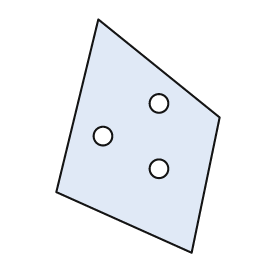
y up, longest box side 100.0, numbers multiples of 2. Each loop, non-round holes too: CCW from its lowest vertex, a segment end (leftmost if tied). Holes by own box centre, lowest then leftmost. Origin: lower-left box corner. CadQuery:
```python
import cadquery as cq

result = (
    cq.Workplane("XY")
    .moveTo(58.0, 0.0)
    .lineTo(70.0, 58.0)
    .lineTo(18.0, 100.0)
    .lineTo(0.0, 26.0)
    .close()
    .moveTo(44.0, 36.0)
    .circle(4.0)
    .moveTo(20.0, 50.0)
    .circle(4.0)
    .moveTo(44.0, 64.0)
    .circle(4.0)
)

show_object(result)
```